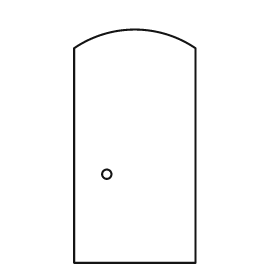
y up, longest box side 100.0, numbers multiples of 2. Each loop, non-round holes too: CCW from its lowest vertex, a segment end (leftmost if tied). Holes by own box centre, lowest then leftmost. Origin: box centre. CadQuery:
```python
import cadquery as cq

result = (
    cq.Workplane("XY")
    .moveTo(-26.0, -50.0)
    .lineTo(26.0, -50.0)
    .lineTo(26.0, 42.0)
    .threePointArc((0.0, 50.0), (-26.0, 42.0))
    .close()
    .moveTo(-12.0, -12.0)
    .circle(2.0)
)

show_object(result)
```